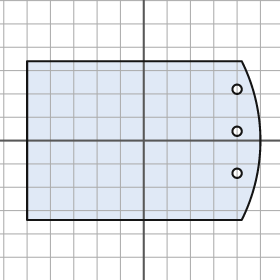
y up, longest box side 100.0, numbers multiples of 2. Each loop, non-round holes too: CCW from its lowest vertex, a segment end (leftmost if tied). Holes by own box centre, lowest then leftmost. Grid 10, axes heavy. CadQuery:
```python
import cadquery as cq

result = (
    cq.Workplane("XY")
    .moveTo(-50.0, -34.0)
    .lineTo(42.0, -34.0)
    .threePointArc((50.0, 0.0), (42.0, 34.0))
    .lineTo(-50.0, 34.0)
    .close()
    .moveTo(40.0, -14.0)
    .circle(2.0)
    .moveTo(40.0, 4.0)
    .circle(2.0)
    .moveTo(40.0, 22.0)
    .circle(2.0)
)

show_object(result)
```